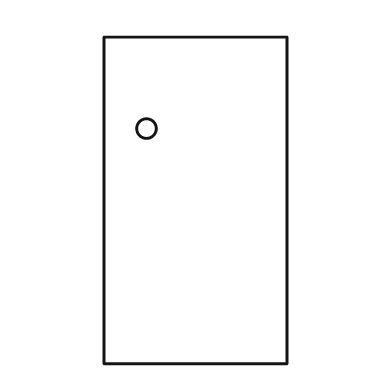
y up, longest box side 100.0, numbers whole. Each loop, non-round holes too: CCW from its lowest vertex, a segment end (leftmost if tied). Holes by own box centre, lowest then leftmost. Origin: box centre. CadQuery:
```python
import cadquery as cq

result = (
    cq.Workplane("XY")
    .moveTo(-28.0, -50.0)
    .lineTo(28.0, -50.0)
    .lineTo(28.0, 50.0)
    .lineTo(-28.0, 50.0)
    .close()
    .moveTo(-15.0, 22.0)
    .circle(3.0)
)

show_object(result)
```